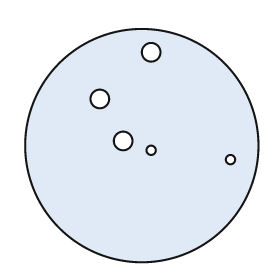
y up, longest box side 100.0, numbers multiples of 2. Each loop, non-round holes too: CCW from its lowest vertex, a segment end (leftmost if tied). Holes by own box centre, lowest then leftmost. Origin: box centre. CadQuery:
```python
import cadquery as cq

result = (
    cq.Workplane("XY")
    .moveTo(0.0, 0.0)
    .circle(50.0)
    .moveTo(38.0, -6.0)
    .circle(2.0)
    .moveTo(4.0, -2.0)
    .circle(2.0)
    .moveTo(-8.0, 2.0)
    .circle(4.0)
    .moveTo(-18.0, 20.0)
    .circle(4.0)
    .moveTo(4.0, 40.0)
    .circle(4.0)
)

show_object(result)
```